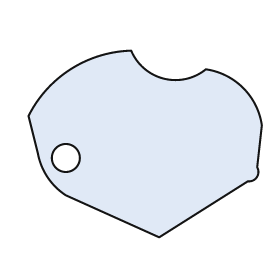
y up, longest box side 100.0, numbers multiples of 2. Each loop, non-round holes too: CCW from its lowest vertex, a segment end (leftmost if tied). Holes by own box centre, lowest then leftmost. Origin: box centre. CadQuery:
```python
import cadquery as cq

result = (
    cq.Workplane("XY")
    .moveTo(6.0, -40.0)
    .lineTo(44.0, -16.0)
    .threePointArc((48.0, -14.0), (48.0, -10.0))
    .lineTo(50.0, 8.0)
    .threePointArc((42.0, 24.0), (26.0, 32.0))
    .threePointArc((8.0, 28.0), (-6.0, 40.0))
    .threePointArc((-32.0, 32.0), (-50.0, 12.0))
    .lineTo(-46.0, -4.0)
    .threePointArc((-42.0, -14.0), (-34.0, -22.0))
    .close()
    .moveTo(-34.0, -6.0)
    .circle(6.0)
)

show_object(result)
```